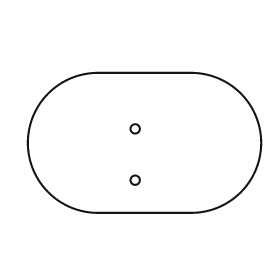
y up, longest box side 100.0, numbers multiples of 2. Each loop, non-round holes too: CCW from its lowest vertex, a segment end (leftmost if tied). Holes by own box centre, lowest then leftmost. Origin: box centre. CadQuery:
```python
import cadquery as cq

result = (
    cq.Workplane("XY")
    .moveTo(-20.0, -30.0)
    .lineTo(20.0, -30.0)
    .threePointArc((50.0, 0.0), (20.0, 30.0))
    .lineTo(-20.0, 30.0)
    .threePointArc((-50.0, 0.0), (-20.0, -30.0))
    .close()
    .moveTo(-4.0, -16.0)
    .circle(2.0)
    .moveTo(-4.0, 6.0)
    .circle(2.0)
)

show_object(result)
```